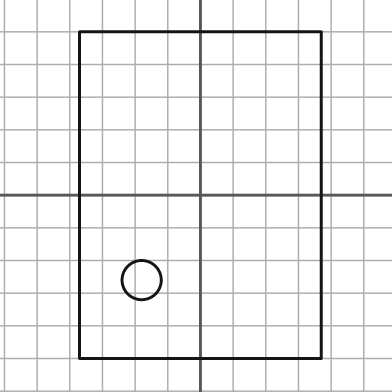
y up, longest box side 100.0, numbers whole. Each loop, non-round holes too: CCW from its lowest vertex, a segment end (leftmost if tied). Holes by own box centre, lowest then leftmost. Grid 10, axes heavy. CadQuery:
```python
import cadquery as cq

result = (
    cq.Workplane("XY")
    .moveTo(-37.0, -50.0)
    .lineTo(37.0, -50.0)
    .lineTo(37.0, 50.0)
    .lineTo(-37.0, 50.0)
    .close()
    .moveTo(-18.0, -26.0)
    .circle(6.0)
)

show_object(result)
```